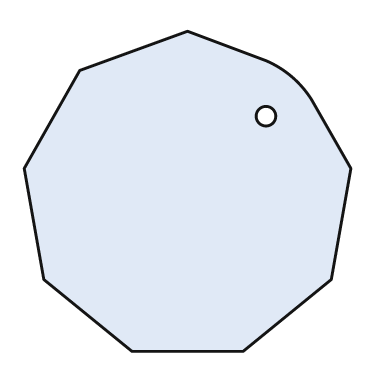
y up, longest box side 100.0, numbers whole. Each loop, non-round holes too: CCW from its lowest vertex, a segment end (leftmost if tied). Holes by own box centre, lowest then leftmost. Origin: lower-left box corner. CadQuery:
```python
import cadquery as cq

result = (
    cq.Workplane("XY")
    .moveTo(33.0, 0.0)
    .lineTo(67.0, 0.0)
    .lineTo(94.0, 22.0)
    .lineTo(100.0, 56.0)
    .lineTo(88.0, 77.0)
    .threePointArc((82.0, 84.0), (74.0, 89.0))
    .lineTo(50.0, 98.0)
    .lineTo(17.0, 86.0)
    .lineTo(0.0, 56.0)
    .lineTo(6.0, 22.0)
    .close()
    .moveTo(74.0, 72.0)
    .circle(3.0)
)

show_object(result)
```